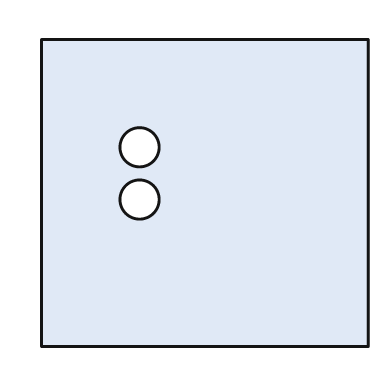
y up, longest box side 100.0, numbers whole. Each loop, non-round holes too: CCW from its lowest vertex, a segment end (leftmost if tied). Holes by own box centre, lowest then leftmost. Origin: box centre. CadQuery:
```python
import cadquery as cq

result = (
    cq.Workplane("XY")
    .moveTo(-50.0, -47.0)
    .lineTo(50.0, -47.0)
    .lineTo(50.0, 47.0)
    .lineTo(-50.0, 47.0)
    .close()
    .moveTo(-20.0, -2.0)
    .circle(6.0)
    .moveTo(-20.0, 14.0)
    .circle(6.0)
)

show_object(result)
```